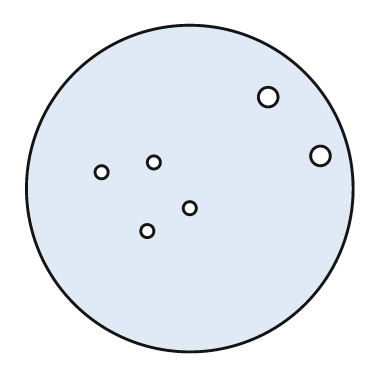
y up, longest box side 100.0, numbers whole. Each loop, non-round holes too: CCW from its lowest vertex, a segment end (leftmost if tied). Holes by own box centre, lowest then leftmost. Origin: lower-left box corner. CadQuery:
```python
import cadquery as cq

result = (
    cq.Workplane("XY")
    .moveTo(50.0, 50.0)
    .circle(50.0)
    .moveTo(37.0, 37.0)
    .circle(2.0)
    .moveTo(50.0, 44.0)
    .circle(2.0)
    .moveTo(23.0, 55.0)
    .circle(2.0)
    .moveTo(39.0, 58.0)
    .circle(2.0)
    .moveTo(90.0, 60.0)
    .circle(3.0)
    .moveTo(74.0, 78.0)
    .circle(3.0)
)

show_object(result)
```